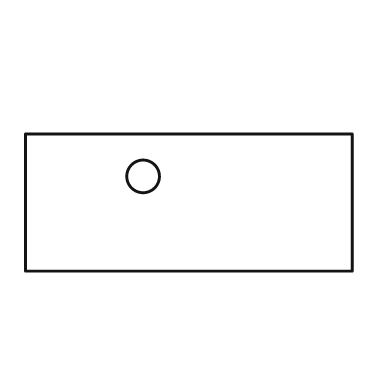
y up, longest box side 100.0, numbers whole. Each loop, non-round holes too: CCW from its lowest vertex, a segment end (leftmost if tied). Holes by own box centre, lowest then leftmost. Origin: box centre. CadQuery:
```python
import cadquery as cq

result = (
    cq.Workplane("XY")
    .moveTo(-50.0, -21.0)
    .lineTo(50.0, -21.0)
    .lineTo(50.0, 21.0)
    .lineTo(-50.0, 21.0)
    .close()
    .moveTo(-14.0, 8.0)
    .circle(5.0)
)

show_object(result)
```